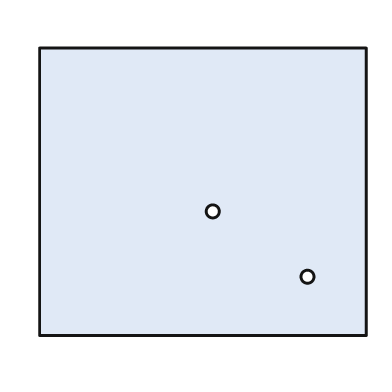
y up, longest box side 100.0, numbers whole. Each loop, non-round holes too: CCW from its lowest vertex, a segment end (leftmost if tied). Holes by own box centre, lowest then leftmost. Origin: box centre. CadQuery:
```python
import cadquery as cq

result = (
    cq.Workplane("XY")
    .moveTo(-50.0, -44.0)
    .lineTo(50.0, -44.0)
    .lineTo(50.0, 44.0)
    .lineTo(-50.0, 44.0)
    .close()
    .moveTo(32.0, -26.0)
    .circle(2.0)
    .moveTo(3.0, -6.0)
    .circle(2.0)
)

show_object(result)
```